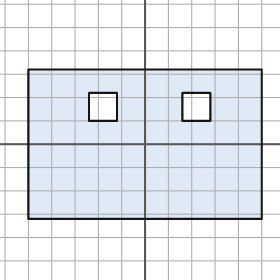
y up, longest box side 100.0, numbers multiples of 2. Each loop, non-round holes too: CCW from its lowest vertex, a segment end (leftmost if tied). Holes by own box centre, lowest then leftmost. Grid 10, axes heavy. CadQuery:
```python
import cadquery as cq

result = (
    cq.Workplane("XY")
    .moveTo(-50.0, -32.0)
    .lineTo(50.0, -32.0)
    .lineTo(50.0, 32.0)
    .lineTo(-50.0, 32.0)
    .close()
    .moveTo(-24.0, 10.0)
    .lineTo(-12.0, 10.0)
    .lineTo(-12.0, 22.0)
    .lineTo(-24.0, 22.0)
    .close()
    .moveTo(16.0, 10.0)
    .lineTo(28.0, 10.0)
    .lineTo(28.0, 22.0)
    .lineTo(16.0, 22.0)
    .close()
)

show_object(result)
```